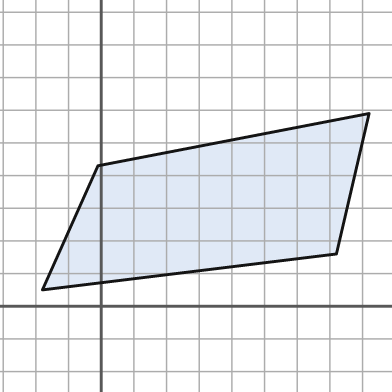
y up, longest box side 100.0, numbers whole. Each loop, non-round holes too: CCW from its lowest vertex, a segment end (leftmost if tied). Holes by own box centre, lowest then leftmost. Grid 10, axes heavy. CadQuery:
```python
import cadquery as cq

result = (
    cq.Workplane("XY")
    .moveTo(-18.0, 5.0)
    .lineTo(72.0, 16.0)
    .lineTo(82.0, 59.0)
    .lineTo(-1.0, 43.0)
    .close()
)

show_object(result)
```